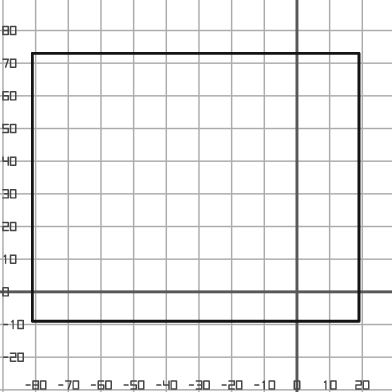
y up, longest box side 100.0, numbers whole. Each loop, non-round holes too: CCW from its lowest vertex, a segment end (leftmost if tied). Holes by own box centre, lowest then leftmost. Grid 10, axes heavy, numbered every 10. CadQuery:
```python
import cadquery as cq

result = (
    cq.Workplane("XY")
    .moveTo(-81.0, -9.0)
    .lineTo(19.0, -9.0)
    .lineTo(19.0, 73.0)
    .lineTo(-81.0, 73.0)
    .close()
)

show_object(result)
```